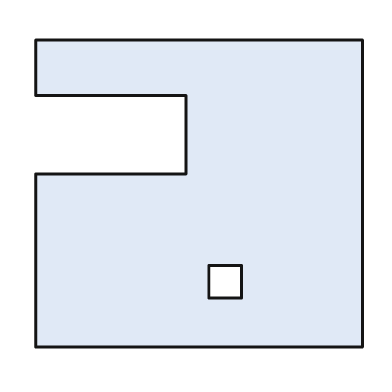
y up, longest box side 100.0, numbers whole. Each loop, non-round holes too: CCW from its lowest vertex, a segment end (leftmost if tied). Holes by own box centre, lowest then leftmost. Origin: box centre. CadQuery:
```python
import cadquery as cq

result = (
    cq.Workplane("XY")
    .moveTo(-50.0, -47.0)
    .lineTo(50.0, -47.0)
    .lineTo(50.0, 47.0)
    .lineTo(-50.0, 47.0)
    .lineTo(-50.0, 30.0)
    .lineTo(-4.0, 30.0)
    .lineTo(-4.0, 6.0)
    .lineTo(-50.0, 6.0)
    .close()
    .moveTo(3.0, -32.0)
    .lineTo(13.0, -32.0)
    .lineTo(13.0, -22.0)
    .lineTo(3.0, -22.0)
    .close()
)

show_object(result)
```